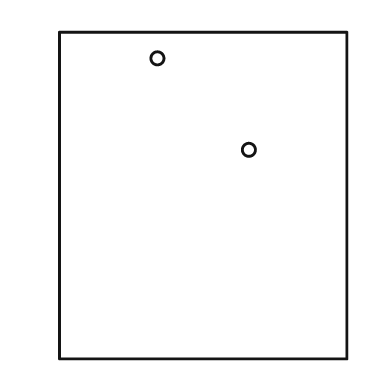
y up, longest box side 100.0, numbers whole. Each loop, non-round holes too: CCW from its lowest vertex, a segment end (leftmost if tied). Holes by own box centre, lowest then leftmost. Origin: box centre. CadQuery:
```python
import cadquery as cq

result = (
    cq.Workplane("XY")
    .moveTo(-44.0, -50.0)
    .lineTo(44.0, -50.0)
    .lineTo(44.0, 50.0)
    .lineTo(-44.0, 50.0)
    .close()
    .moveTo(14.0, 14.0)
    .circle(2.0)
    .moveTo(-14.0, 42.0)
    .circle(2.0)
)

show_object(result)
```